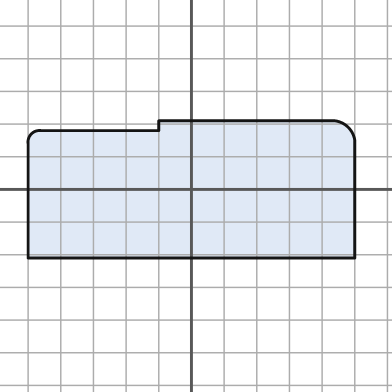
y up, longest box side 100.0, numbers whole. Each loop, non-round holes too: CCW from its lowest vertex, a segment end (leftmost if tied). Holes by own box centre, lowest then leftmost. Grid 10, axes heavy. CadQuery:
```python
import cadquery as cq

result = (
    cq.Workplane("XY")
    .moveTo(-50.0, -21.0)
    .lineTo(50.0, -21.0)
    .lineTo(50.0, 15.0)
    .threePointArc((48.0, 19.0), (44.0, 21.0))
    .lineTo(-10.0, 21.0)
    .lineTo(-10.0, 18.0)
    .lineTo(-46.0, 18.0)
    .threePointArc((-49.0, 17.0), (-50.0, 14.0))
    .close()
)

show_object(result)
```